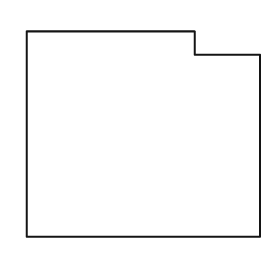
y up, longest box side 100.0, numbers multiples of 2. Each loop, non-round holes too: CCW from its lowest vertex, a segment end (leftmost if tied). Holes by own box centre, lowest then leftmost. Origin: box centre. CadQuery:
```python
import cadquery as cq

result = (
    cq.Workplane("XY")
    .moveTo(-50.0, -44.0)
    .lineTo(50.0, -44.0)
    .lineTo(50.0, 34.0)
    .lineTo(22.0, 34.0)
    .lineTo(22.0, 44.0)
    .lineTo(-50.0, 44.0)
    .close()
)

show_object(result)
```